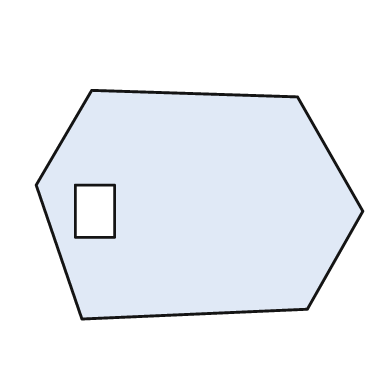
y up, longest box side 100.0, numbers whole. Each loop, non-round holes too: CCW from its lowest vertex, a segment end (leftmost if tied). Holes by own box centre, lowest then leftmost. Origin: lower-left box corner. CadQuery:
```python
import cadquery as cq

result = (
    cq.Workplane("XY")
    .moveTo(14.0, 0.0)
    .lineTo(83.0, 3.0)
    .lineTo(100.0, 33.0)
    .lineTo(80.0, 68.0)
    .lineTo(17.0, 70.0)
    .lineTo(0.0, 41.0)
    .close()
    .moveTo(12.0, 25.0)
    .lineTo(24.0, 25.0)
    .lineTo(24.0, 41.0)
    .lineTo(12.0, 41.0)
    .close()
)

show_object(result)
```